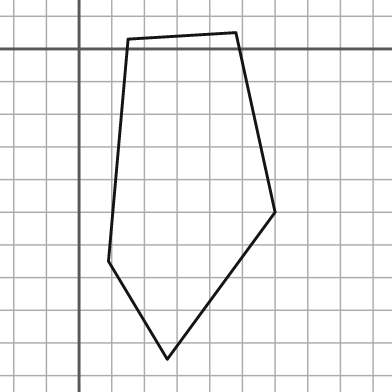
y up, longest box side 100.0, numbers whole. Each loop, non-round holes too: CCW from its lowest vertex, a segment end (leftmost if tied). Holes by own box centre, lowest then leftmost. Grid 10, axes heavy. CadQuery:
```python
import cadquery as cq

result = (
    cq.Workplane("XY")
    .moveTo(27.0, -95.0)
    .lineTo(60.0, -50.0)
    .lineTo(48.0, 5.0)
    .lineTo(15.0, 3.0)
    .lineTo(9.0, -65.0)
    .close()
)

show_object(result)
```